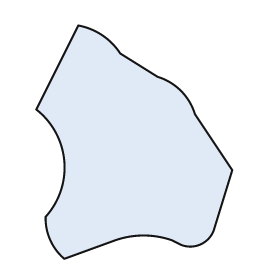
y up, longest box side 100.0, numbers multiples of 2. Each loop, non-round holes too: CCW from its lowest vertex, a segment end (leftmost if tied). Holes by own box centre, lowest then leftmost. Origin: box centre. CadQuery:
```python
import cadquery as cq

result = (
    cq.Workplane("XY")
    .moveTo(-30.0, -50.0)
    .lineTo(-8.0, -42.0)
    .threePointArc((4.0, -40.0), (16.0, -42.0))
    .lineTo(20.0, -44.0)
    .threePointArc((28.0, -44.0), (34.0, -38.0))
    .lineTo(42.0, -12.0)
    .lineTo(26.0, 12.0)
    .threePointArc((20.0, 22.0), (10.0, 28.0))
    .lineTo(-6.0, 38.0)
    .threePointArc((-14.0, 46.0), (-24.0, 50.0))
    .lineTo(-42.0, 14.0)
    .threePointArc((-30.0, -8.0), (-38.0, -32.0))
    .threePointArc((-36.0, -42.0), (-30.0, -50.0))
    .close()
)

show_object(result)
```